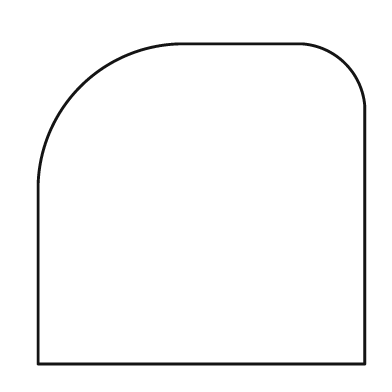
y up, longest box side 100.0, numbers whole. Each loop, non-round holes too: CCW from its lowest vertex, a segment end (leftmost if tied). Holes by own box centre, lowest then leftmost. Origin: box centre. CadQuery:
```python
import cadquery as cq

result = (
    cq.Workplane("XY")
    .moveTo(-50.0, -49.0)
    .lineTo(50.0, -49.0)
    .lineTo(50.0, 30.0)
    .threePointArc((44.0, 43.0), (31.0, 49.0))
    .lineTo(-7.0, 49.0)
    .threePointArc((-37.0, 36.0), (-50.0, 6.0))
    .close()
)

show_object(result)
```